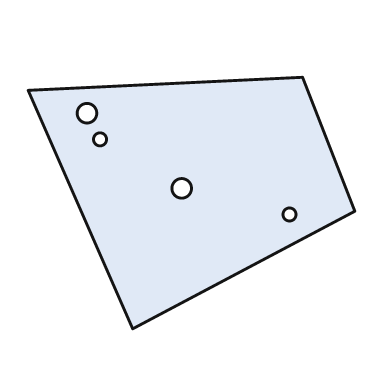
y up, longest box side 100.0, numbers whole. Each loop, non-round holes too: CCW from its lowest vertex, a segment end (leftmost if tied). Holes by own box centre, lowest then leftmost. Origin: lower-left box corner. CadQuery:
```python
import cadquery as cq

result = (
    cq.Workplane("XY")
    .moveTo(32.0, 0.0)
    .lineTo(100.0, 36.0)
    .lineTo(84.0, 77.0)
    .lineTo(0.0, 73.0)
    .close()
    .moveTo(80.0, 35.0)
    .circle(2.0)
    .moveTo(47.0, 43.0)
    .circle(3.0)
    .moveTo(22.0, 58.0)
    .circle(2.0)
    .moveTo(18.0, 66.0)
    .circle(3.0)
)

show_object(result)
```